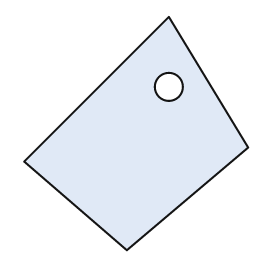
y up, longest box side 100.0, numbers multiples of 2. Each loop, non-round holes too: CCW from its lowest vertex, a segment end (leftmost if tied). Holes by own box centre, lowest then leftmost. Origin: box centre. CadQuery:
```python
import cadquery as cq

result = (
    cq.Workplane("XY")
    .moveTo(-4.0, -50.0)
    .lineTo(48.0, -6.0)
    .lineTo(14.0, 50.0)
    .lineTo(-48.0, -12.0)
    .close()
    .moveTo(14.0, 20.0)
    .circle(6.0)
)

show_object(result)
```